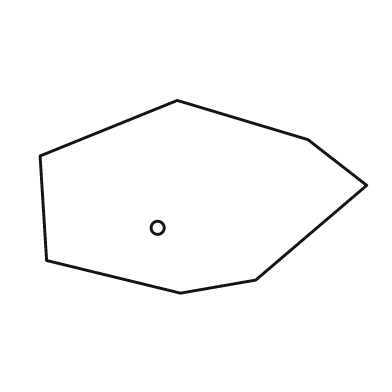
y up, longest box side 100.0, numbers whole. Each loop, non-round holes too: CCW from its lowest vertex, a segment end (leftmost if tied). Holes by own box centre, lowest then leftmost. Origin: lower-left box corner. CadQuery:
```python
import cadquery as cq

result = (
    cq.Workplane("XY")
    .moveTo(43.0, 0.0)
    .lineTo(66.0, 4.0)
    .lineTo(100.0, 33.0)
    .lineTo(82.0, 47.0)
    .lineTo(42.0, 59.0)
    .lineTo(0.0, 42.0)
    .lineTo(2.0, 10.0)
    .close()
    .moveTo(36.0, 20.0)
    .circle(2.0)
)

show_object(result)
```